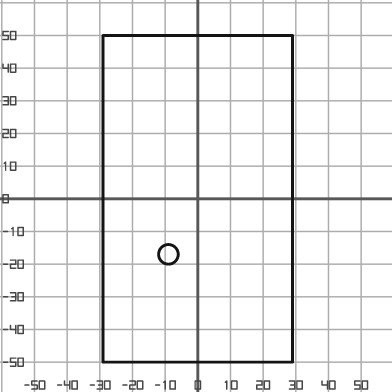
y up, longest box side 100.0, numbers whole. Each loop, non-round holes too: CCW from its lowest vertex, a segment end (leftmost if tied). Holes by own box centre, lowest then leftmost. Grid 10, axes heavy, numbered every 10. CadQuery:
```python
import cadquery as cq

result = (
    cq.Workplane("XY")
    .moveTo(-29.0, -50.0)
    .lineTo(29.0, -50.0)
    .lineTo(29.0, 50.0)
    .lineTo(-29.0, 50.0)
    .close()
    .moveTo(-9.0, -17.0)
    .circle(3.0)
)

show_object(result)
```